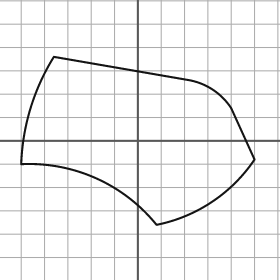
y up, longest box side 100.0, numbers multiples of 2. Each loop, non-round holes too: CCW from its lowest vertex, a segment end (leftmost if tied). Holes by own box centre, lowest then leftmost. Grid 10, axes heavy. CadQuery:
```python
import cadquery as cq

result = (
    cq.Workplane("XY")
    .moveTo(8.0, -36.0)
    .threePointArc((32.0, -26.0), (50.0, -8.0))
    .lineTo(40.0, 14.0)
    .threePointArc((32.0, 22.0), (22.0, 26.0))
    .lineTo(-36.0, 36.0)
    .threePointArc((-46.0, 14.0), (-50.0, -10.0))
    .threePointArc((-18.0, -16.0), (8.0, -36.0))
    .close()
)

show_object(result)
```